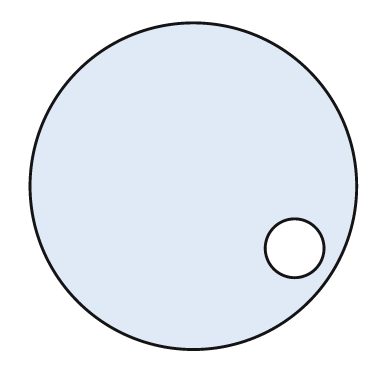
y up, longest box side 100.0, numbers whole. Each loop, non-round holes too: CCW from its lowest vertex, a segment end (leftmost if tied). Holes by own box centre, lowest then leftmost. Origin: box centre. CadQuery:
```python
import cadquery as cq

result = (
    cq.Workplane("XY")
    .moveTo(0.0, 0.0)
    .circle(50.0)
    .moveTo(31.0, -19.0)
    .circle(9.0)
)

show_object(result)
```